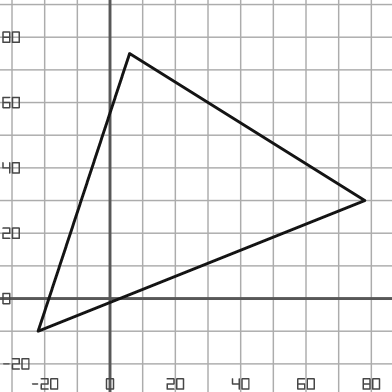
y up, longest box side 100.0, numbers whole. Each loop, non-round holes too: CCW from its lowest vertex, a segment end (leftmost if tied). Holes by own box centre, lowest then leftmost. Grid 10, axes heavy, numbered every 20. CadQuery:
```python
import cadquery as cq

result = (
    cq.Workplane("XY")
    .moveTo(-22.0, -10.0)
    .lineTo(78.0, 30.0)
    .lineTo(6.0, 75.0)
    .close()
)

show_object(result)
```